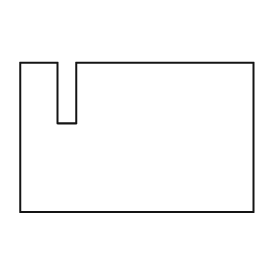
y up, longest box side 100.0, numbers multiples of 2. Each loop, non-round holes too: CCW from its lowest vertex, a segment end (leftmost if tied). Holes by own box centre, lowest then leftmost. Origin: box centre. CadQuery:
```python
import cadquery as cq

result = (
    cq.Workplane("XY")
    .moveTo(-50.0, -32.0)
    .lineTo(50.0, -32.0)
    .lineTo(50.0, 32.0)
    .lineTo(-26.0, 32.0)
    .lineTo(-26.0, 6.0)
    .lineTo(-34.0, 6.0)
    .lineTo(-34.0, 32.0)
    .lineTo(-50.0, 32.0)
    .close()
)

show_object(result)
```